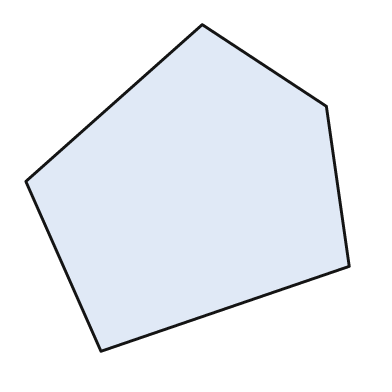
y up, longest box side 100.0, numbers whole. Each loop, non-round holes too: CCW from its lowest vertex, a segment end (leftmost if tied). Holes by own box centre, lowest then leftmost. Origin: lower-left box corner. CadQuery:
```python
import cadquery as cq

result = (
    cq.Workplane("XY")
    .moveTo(23.0, 0.0)
    .lineTo(99.0, 26.0)
    .lineTo(92.0, 75.0)
    .lineTo(54.0, 100.0)
    .lineTo(0.0, 52.0)
    .close()
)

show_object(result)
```